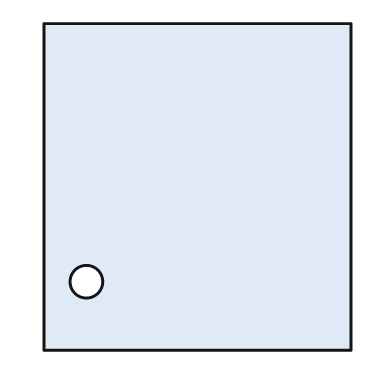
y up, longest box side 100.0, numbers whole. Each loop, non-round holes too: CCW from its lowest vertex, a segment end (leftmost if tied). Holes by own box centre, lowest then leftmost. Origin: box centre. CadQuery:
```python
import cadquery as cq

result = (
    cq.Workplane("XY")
    .moveTo(-47.0, -50.0)
    .lineTo(47.0, -50.0)
    .lineTo(47.0, 50.0)
    .lineTo(-47.0, 50.0)
    .close()
    .moveTo(-34.0, -29.0)
    .circle(5.0)
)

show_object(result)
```